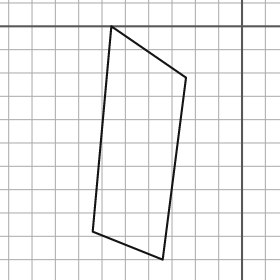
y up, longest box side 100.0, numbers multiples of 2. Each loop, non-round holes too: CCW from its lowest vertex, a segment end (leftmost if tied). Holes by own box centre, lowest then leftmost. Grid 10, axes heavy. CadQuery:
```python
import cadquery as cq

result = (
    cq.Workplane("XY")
    .moveTo(-34.0, -100.0)
    .lineTo(-24.0, -22.0)
    .lineTo(-56.0, 0.0)
    .lineTo(-64.0, -88.0)
    .close()
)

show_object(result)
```